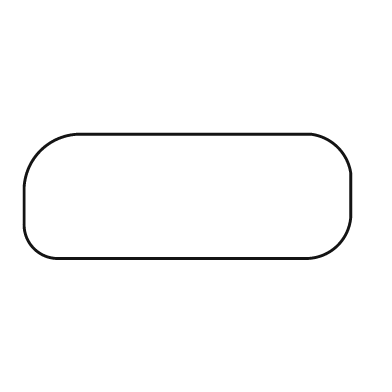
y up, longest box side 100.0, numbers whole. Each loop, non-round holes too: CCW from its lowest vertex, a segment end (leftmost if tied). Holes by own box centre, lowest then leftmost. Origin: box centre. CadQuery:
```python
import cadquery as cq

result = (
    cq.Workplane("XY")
    .moveTo(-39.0, -19.0)
    .lineTo(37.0, -19.0)
    .threePointArc((46.0, -15.0), (50.0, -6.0))
    .lineTo(50.0, 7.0)
    .threePointArc((46.0, 15.0), (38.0, 19.0))
    .lineTo(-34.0, 19.0)
    .threePointArc((-45.0, 14.0), (-50.0, 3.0))
    .lineTo(-50.0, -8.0)
    .threePointArc((-47.0, -16.0), (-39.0, -19.0))
    .close()
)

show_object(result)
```